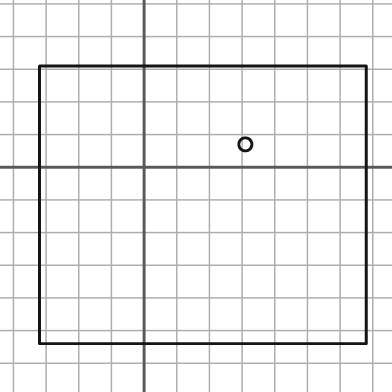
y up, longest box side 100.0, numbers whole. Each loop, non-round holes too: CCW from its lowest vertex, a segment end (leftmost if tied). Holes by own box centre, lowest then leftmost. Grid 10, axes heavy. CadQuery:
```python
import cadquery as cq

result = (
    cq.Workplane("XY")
    .moveTo(-32.0, -54.0)
    .lineTo(68.0, -54.0)
    .lineTo(68.0, 31.0)
    .lineTo(-32.0, 31.0)
    .close()
    .moveTo(31.0, 7.0)
    .circle(2.0)
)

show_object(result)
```